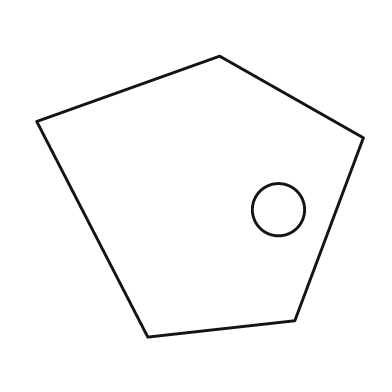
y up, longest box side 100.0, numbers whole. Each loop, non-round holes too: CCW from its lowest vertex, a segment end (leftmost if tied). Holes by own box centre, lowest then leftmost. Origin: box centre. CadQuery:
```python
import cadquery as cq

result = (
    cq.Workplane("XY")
    .moveTo(-16.0, -43.0)
    .lineTo(29.0, -38.0)
    .lineTo(50.0, 18.0)
    .lineTo(6.0, 43.0)
    .lineTo(-50.0, 23.0)
    .close()
    .moveTo(24.0, -4.0)
    .circle(8.0)
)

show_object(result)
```